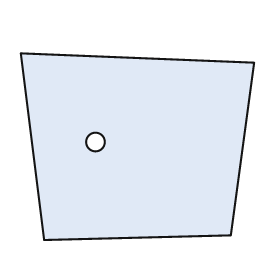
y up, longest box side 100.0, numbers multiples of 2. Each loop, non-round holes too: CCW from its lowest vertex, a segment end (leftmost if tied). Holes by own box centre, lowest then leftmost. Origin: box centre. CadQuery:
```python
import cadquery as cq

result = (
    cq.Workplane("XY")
    .moveTo(-40.0, -40.0)
    .lineTo(40.0, -38.0)
    .lineTo(50.0, 36.0)
    .lineTo(-50.0, 40.0)
    .close()
    .moveTo(-18.0, 2.0)
    .circle(4.0)
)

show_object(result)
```